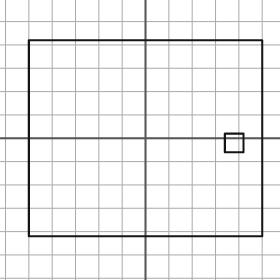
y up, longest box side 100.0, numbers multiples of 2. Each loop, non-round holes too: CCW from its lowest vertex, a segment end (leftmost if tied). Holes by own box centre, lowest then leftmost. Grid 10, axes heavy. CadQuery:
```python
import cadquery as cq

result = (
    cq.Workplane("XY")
    .moveTo(-50.0, -42.0)
    .lineTo(50.0, -42.0)
    .lineTo(50.0, 42.0)
    .lineTo(-50.0, 42.0)
    .close()
    .moveTo(34.0, -6.0)
    .lineTo(42.0, -6.0)
    .lineTo(42.0, 2.0)
    .lineTo(34.0, 2.0)
    .close()
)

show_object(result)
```